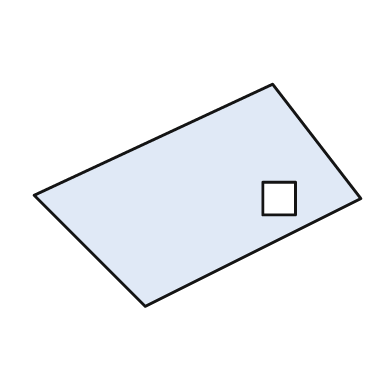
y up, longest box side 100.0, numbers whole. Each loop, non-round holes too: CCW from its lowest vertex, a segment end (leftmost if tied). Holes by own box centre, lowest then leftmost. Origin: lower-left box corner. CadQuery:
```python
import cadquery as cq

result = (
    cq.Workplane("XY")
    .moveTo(34.0, 0.0)
    .lineTo(100.0, 33.0)
    .lineTo(73.0, 68.0)
    .lineTo(0.0, 34.0)
    .close()
    .moveTo(70.0, 28.0)
    .lineTo(80.0, 28.0)
    .lineTo(80.0, 38.0)
    .lineTo(70.0, 38.0)
    .close()
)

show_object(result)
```